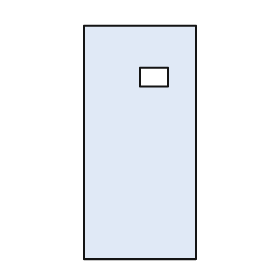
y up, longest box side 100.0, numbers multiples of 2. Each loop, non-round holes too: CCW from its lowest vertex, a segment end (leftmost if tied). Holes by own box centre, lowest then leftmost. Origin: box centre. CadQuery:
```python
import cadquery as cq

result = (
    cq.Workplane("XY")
    .moveTo(-24.0, -50.0)
    .lineTo(24.0, -50.0)
    .lineTo(24.0, 50.0)
    .lineTo(-24.0, 50.0)
    .close()
    .moveTo(0.0, 24.0)
    .lineTo(12.0, 24.0)
    .lineTo(12.0, 32.0)
    .lineTo(0.0, 32.0)
    .close()
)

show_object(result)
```